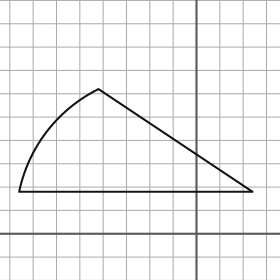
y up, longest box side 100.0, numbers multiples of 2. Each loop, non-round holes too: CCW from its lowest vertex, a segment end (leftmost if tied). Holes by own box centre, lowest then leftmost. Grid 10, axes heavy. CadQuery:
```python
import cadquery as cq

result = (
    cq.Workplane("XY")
    .moveTo(-76.0, 18.0)
    .lineTo(24.0, 18.0)
    .lineTo(-42.0, 62.0)
    .threePointArc((-64.0, 44.0), (-76.0, 18.0))
    .close()
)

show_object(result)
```